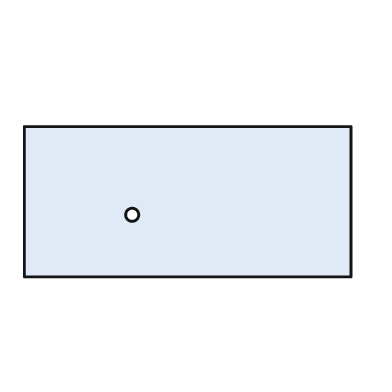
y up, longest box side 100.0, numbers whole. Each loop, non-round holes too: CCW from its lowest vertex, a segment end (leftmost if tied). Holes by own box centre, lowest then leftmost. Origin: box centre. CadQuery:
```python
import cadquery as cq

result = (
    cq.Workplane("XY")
    .moveTo(-50.0, -23.0)
    .lineTo(50.0, -23.0)
    .lineTo(50.0, 23.0)
    .lineTo(-50.0, 23.0)
    .close()
    .moveTo(-17.0, -4.0)
    .circle(2.0)
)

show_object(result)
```